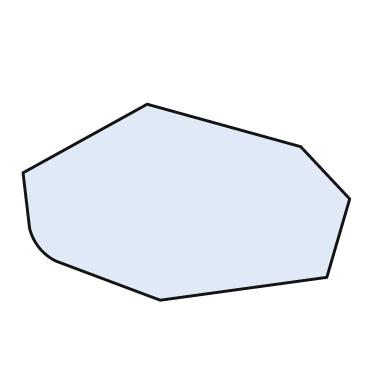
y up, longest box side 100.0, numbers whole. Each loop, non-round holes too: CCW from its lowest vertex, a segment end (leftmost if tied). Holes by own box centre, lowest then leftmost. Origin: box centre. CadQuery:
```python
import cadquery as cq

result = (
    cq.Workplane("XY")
    .moveTo(-8.0, -30.0)
    .lineTo(43.0, -23.0)
    .lineTo(50.0, 1.0)
    .lineTo(35.0, 17.0)
    .lineTo(-12.0, 30.0)
    .lineTo(-50.0, 9.0)
    .lineTo(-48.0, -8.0)
    .threePointArc((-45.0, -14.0), (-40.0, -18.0))
    .close()
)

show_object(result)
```